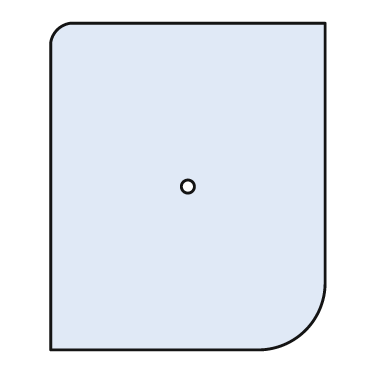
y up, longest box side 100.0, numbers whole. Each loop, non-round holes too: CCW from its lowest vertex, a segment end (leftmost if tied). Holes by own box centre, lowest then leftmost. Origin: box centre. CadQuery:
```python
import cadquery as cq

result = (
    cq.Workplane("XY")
    .moveTo(-42.0, -50.0)
    .lineTo(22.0, -50.0)
    .threePointArc((36.0, -44.0), (42.0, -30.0))
    .lineTo(42.0, 50.0)
    .lineTo(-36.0, 50.0)
    .threePointArc((-40.0, 48.0), (-42.0, 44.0))
    .close()
    .moveTo(0.0, 0.0)
    .circle(2.0)
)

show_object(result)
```